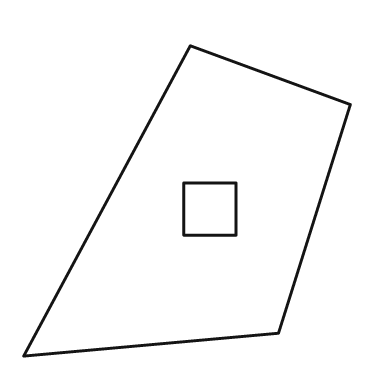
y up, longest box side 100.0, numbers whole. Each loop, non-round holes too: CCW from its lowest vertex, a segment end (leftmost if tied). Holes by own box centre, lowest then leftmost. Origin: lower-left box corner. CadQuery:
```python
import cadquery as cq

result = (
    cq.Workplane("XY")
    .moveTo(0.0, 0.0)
    .lineTo(78.0, 7.0)
    .lineTo(100.0, 77.0)
    .lineTo(51.0, 95.0)
    .close()
    .moveTo(49.0, 37.0)
    .lineTo(65.0, 37.0)
    .lineTo(65.0, 53.0)
    .lineTo(49.0, 53.0)
    .close()
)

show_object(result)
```